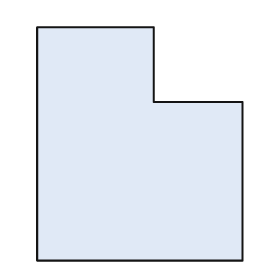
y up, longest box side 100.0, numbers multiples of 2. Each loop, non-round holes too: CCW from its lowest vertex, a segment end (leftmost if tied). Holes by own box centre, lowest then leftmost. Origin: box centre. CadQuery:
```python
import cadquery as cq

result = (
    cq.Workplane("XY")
    .moveTo(-44.0, -50.0)
    .lineTo(44.0, -50.0)
    .lineTo(44.0, 18.0)
    .lineTo(6.0, 18.0)
    .lineTo(6.0, 50.0)
    .lineTo(-44.0, 50.0)
    .close()
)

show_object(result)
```